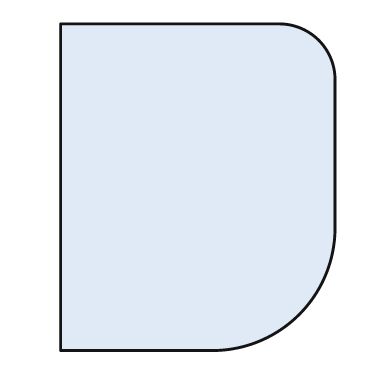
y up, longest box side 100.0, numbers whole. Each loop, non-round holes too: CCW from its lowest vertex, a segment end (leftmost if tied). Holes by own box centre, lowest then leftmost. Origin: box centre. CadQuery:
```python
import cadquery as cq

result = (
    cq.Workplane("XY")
    .moveTo(-42.0, -50.0)
    .lineTo(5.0, -50.0)
    .threePointArc((31.0, -39.0), (42.0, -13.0))
    .lineTo(42.0, 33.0)
    .threePointArc((37.0, 45.0), (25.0, 50.0))
    .lineTo(-42.0, 50.0)
    .close()
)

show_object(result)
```